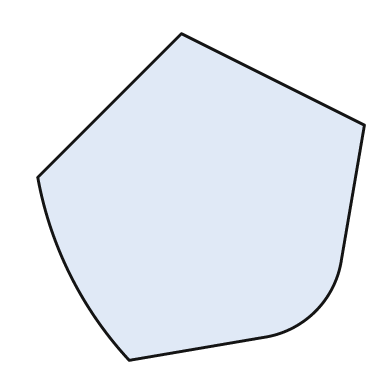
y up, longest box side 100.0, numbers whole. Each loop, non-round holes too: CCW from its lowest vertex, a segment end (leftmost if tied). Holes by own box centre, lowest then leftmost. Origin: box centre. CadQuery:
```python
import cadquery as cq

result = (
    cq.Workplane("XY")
    .moveTo(-22.0, -50.0)
    .lineTo(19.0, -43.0)
    .threePointArc((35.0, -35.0), (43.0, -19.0))
    .lineTo(50.0, 22.0)
    .lineTo(-6.0, 50.0)
    .lineTo(-50.0, 6.0)
    .threePointArc((-40.0, -24.0), (-22.0, -50.0))
    .close()
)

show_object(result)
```